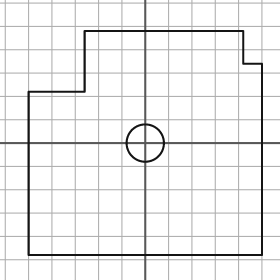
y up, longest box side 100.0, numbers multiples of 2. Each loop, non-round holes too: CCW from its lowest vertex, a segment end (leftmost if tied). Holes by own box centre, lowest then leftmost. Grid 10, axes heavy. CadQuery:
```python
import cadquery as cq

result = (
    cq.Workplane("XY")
    .moveTo(-50.0, -48.0)
    .lineTo(50.0, -48.0)
    .lineTo(50.0, 34.0)
    .lineTo(42.0, 34.0)
    .lineTo(42.0, 48.0)
    .lineTo(-26.0, 48.0)
    .lineTo(-26.0, 22.0)
    .lineTo(-50.0, 22.0)
    .close()
    .moveTo(0.0, 0.0)
    .circle(8.0)
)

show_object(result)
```